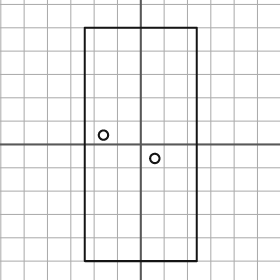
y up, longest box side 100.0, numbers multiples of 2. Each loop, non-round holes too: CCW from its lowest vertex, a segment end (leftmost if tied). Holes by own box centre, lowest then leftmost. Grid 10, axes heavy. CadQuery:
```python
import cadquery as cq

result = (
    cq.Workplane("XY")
    .moveTo(-24.0, -50.0)
    .lineTo(24.0, -50.0)
    .lineTo(24.0, 50.0)
    .lineTo(-24.0, 50.0)
    .close()
    .moveTo(6.0, -6.0)
    .circle(2.0)
    .moveTo(-16.0, 4.0)
    .circle(2.0)
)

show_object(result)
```